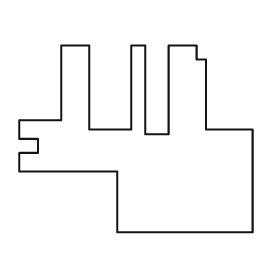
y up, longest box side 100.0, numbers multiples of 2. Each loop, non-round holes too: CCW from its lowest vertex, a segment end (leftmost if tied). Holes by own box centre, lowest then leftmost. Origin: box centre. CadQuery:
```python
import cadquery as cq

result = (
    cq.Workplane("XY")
    .moveTo(-8.0, -40.0)
    .lineTo(50.0, -40.0)
    .lineTo(50.0, 4.0)
    .lineTo(30.0, 4.0)
    .lineTo(30.0, 34.0)
    .lineTo(26.0, 34.0)
    .lineTo(26.0, 40.0)
    .lineTo(14.0, 40.0)
    .lineTo(14.0, 2.0)
    .lineTo(4.0, 2.0)
    .lineTo(4.0, 40.0)
    .lineTo(-2.0, 40.0)
    .lineTo(-2.0, 4.0)
    .lineTo(-20.0, 4.0)
    .lineTo(-20.0, 40.0)
    .lineTo(-32.0, 40.0)
    .lineTo(-32.0, 8.0)
    .lineTo(-50.0, 8.0)
    .lineTo(-50.0, 0.0)
    .lineTo(-42.0, 0.0)
    .lineTo(-42.0, -6.0)
    .lineTo(-50.0, -6.0)
    .lineTo(-50.0, -14.0)
    .lineTo(-8.0, -14.0)
    .close()
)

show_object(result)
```